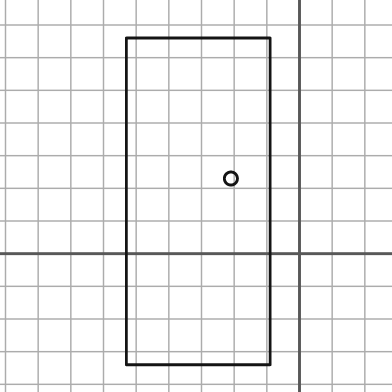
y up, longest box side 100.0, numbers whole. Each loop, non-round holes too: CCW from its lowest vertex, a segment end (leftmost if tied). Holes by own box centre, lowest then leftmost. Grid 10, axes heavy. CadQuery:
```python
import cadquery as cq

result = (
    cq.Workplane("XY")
    .moveTo(-53.0, -34.0)
    .lineTo(-9.0, -34.0)
    .lineTo(-9.0, 66.0)
    .lineTo(-53.0, 66.0)
    .close()
    .moveTo(-21.0, 23.0)
    .circle(2.0)
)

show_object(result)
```